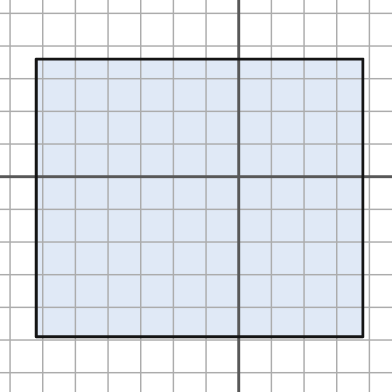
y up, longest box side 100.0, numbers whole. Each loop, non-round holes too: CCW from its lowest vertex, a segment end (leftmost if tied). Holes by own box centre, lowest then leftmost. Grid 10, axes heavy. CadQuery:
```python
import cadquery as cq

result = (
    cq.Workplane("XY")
    .moveTo(-62.0, -49.0)
    .lineTo(38.0, -49.0)
    .lineTo(38.0, 36.0)
    .lineTo(-62.0, 36.0)
    .close()
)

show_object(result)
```